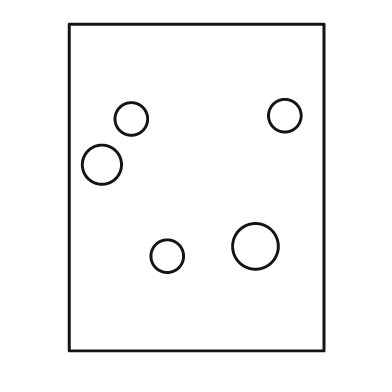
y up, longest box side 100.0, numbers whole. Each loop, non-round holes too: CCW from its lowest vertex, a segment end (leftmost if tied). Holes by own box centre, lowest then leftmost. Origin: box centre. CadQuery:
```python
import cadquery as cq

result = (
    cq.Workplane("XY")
    .moveTo(-39.0, -50.0)
    .lineTo(39.0, -50.0)
    .lineTo(39.0, 50.0)
    .lineTo(-39.0, 50.0)
    .close()
    .moveTo(-9.0, -21.0)
    .circle(5.0)
    .moveTo(18.0, -18.0)
    .circle(7.0)
    .moveTo(-29.0, 7.0)
    .circle(6.0)
    .moveTo(-20.0, 21.0)
    .circle(5.0)
    .moveTo(27.0, 22.0)
    .circle(5.0)
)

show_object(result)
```